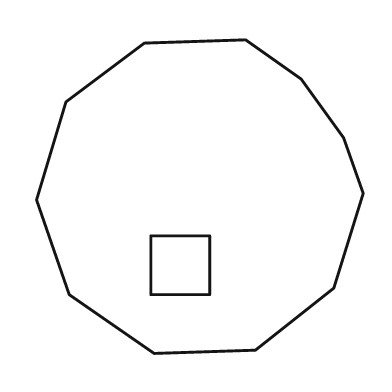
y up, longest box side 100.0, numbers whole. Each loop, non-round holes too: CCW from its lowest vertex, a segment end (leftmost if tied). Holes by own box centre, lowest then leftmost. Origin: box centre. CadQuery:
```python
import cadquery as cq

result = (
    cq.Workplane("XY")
    .moveTo(-14.0, -48.0)
    .lineTo(17.0, -47.0)
    .lineTo(41.0, -28.0)
    .lineTo(50.0, 1.0)
    .lineTo(44.0, 18.0)
    .lineTo(31.0, 36.0)
    .lineTo(14.0, 48.0)
    .lineTo(-17.0, 47.0)
    .lineTo(-41.0, 29.0)
    .lineTo(-50.0, -1.0)
    .lineTo(-40.0, -30.0)
    .close()
    .moveTo(-15.0, -30.0)
    .lineTo(3.0, -30.0)
    .lineTo(3.0, -12.0)
    .lineTo(-15.0, -12.0)
    .close()
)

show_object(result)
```